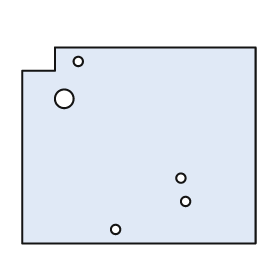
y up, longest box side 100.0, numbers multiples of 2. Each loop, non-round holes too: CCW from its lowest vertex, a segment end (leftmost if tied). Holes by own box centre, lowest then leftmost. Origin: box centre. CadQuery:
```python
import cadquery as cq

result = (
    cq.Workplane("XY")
    .moveTo(-50.0, -42.0)
    .lineTo(50.0, -42.0)
    .lineTo(50.0, 42.0)
    .lineTo(-36.0, 42.0)
    .lineTo(-36.0, 32.0)
    .lineTo(-50.0, 32.0)
    .close()
    .moveTo(-10.0, -36.0)
    .circle(2.0)
    .moveTo(20.0, -24.0)
    .circle(2.0)
    .moveTo(18.0, -14.0)
    .circle(2.0)
    .moveTo(-32.0, 20.0)
    .circle(4.0)
    .moveTo(-26.0, 36.0)
    .circle(2.0)
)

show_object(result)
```